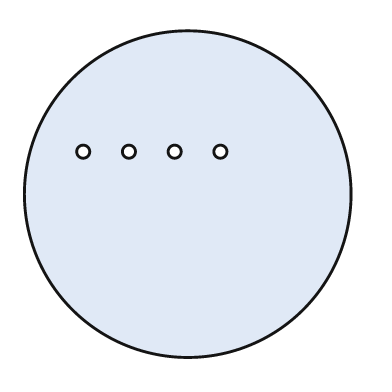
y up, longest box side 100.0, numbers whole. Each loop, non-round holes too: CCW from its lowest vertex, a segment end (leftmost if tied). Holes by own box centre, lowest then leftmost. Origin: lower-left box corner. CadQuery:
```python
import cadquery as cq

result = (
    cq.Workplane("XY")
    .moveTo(50.0, 50.0)
    .circle(50.0)
    .moveTo(18.0, 63.0)
    .circle(2.0)
    .moveTo(32.0, 63.0)
    .circle(2.0)
    .moveTo(46.0, 63.0)
    .circle(2.0)
    .moveTo(60.0, 63.0)
    .circle(2.0)
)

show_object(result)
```